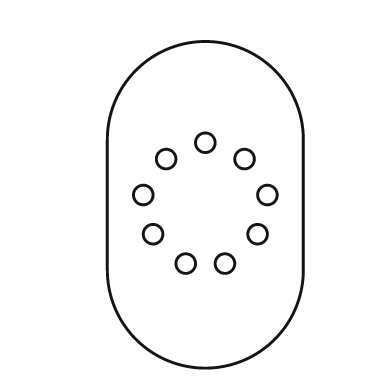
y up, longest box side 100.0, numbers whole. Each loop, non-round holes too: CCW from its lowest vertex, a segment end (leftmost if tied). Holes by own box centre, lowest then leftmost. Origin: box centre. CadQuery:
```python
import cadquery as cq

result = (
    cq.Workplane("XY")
    .moveTo(-30.0, -20.0)
    .threePointArc((0.0, -50.0), (30.0, -20.0))
    .lineTo(30.0, 20.0)
    .threePointArc((0.0, 50.0), (-30.0, 20.0))
    .close()
    .moveTo(-6.0, -18.0)
    .circle(3.0)
    .moveTo(6.0, -18.0)
    .circle(3.0)
    .moveTo(-16.0, -9.0)
    .circle(3.0)
    .moveTo(16.0, -9.0)
    .circle(3.0)
    .moveTo(-19.0, 3.0)
    .circle(3.0)
    .moveTo(19.0, 3.0)
    .circle(3.0)
    .moveTo(-12.0, 14.0)
    .circle(3.0)
    .moveTo(12.0, 14.0)
    .circle(3.0)
    .moveTo(0.0, 19.0)
    .circle(3.0)
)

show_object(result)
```